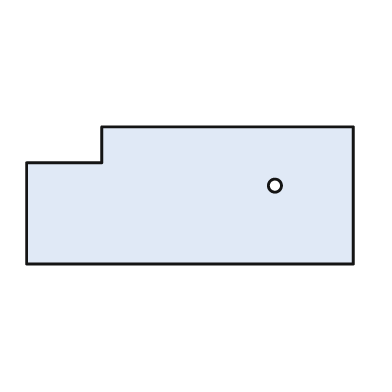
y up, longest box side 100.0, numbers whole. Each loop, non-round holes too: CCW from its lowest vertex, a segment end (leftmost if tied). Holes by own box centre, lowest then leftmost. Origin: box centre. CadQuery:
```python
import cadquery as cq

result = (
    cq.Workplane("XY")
    .moveTo(-50.0, -21.0)
    .lineTo(50.0, -21.0)
    .lineTo(50.0, 21.0)
    .lineTo(-27.0, 21.0)
    .lineTo(-27.0, 10.0)
    .lineTo(-50.0, 10.0)
    .close()
    .moveTo(26.0, 3.0)
    .circle(2.0)
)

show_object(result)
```